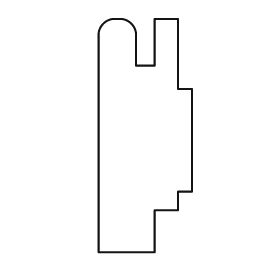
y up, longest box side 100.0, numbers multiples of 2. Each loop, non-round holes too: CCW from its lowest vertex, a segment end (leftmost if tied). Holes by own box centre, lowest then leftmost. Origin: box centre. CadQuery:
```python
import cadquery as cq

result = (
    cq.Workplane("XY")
    .moveTo(-20.0, -50.0)
    .lineTo(4.0, -50.0)
    .lineTo(4.0, -32.0)
    .lineTo(14.0, -32.0)
    .lineTo(14.0, -24.0)
    .lineTo(20.0, -24.0)
    .lineTo(20.0, 20.0)
    .lineTo(14.0, 20.0)
    .lineTo(14.0, 50.0)
    .lineTo(4.0, 50.0)
    .lineTo(4.0, 30.0)
    .lineTo(-4.0, 30.0)
    .lineTo(-4.0, 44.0)
    .threePointArc((-6.0, 48.0), (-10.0, 50.0))
    .lineTo(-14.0, 50.0)
    .threePointArc((-18.0, 48.0), (-20.0, 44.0))
    .close()
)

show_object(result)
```